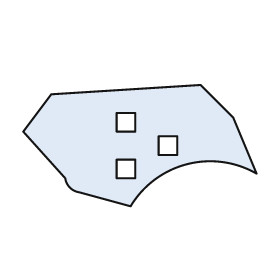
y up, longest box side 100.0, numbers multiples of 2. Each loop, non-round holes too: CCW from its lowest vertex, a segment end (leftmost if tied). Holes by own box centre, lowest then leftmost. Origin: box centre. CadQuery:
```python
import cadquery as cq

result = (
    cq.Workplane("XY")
    .moveTo(-4.0, -26.0)
    .threePointArc((20.0, -8.0), (50.0, -12.0))
    .lineTo(40.0, 12.0)
    .lineTo(26.0, 26.0)
    .lineTo(-38.0, 22.0)
    .lineTo(-50.0, 6.0)
    .lineTo(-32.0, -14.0)
    .threePointArc((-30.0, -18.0), (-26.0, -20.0))
    .close()
    .moveTo(-10.0, -14.0)
    .lineTo(-2.0, -14.0)
    .lineTo(-2.0, -6.0)
    .lineTo(-10.0, -6.0)
    .close()
    .moveTo(8.0, -4.0)
    .lineTo(16.0, -4.0)
    .lineTo(16.0, 4.0)
    .lineTo(8.0, 4.0)
    .close()
    .moveTo(-10.0, 6.0)
    .lineTo(-2.0, 6.0)
    .lineTo(-2.0, 14.0)
    .lineTo(-10.0, 14.0)
    .close()
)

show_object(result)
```